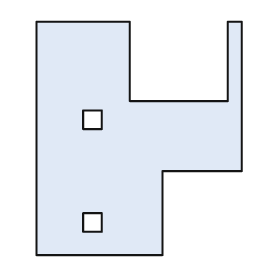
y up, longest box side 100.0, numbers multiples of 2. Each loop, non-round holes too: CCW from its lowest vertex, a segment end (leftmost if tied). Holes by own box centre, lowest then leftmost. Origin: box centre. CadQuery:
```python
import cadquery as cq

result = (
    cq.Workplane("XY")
    .moveTo(-44.0, -50.0)
    .lineTo(10.0, -50.0)
    .lineTo(10.0, -14.0)
    .lineTo(44.0, -14.0)
    .lineTo(44.0, 50.0)
    .lineTo(38.0, 50.0)
    .lineTo(38.0, 16.0)
    .lineTo(-4.0, 16.0)
    .lineTo(-4.0, 50.0)
    .lineTo(-44.0, 50.0)
    .close()
    .moveTo(-24.0, -40.0)
    .lineTo(-16.0, -40.0)
    .lineTo(-16.0, -32.0)
    .lineTo(-24.0, -32.0)
    .close()
    .moveTo(-24.0, 4.0)
    .lineTo(-16.0, 4.0)
    .lineTo(-16.0, 12.0)
    .lineTo(-24.0, 12.0)
    .close()
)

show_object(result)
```